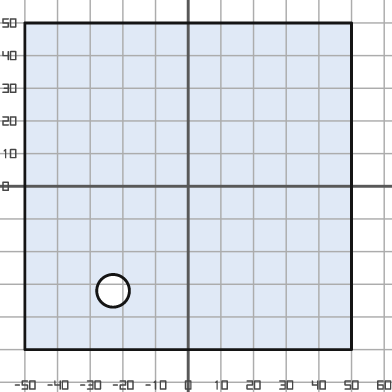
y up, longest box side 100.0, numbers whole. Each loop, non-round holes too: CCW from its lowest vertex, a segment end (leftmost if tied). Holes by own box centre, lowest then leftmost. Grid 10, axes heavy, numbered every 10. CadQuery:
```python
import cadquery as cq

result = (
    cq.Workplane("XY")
    .moveTo(-50.0, -50.0)
    .lineTo(50.0, -50.0)
    .lineTo(50.0, 50.0)
    .lineTo(-50.0, 50.0)
    .close()
    .moveTo(-23.0, -32.0)
    .circle(5.0)
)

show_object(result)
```